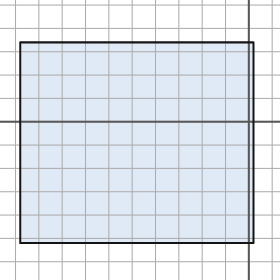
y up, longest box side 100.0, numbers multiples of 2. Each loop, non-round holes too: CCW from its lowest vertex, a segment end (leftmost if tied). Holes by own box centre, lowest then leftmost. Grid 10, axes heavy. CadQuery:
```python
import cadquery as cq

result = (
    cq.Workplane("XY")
    .moveTo(-98.0, -52.0)
    .lineTo(2.0, -52.0)
    .lineTo(2.0, 34.0)
    .lineTo(-98.0, 34.0)
    .close()
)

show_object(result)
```